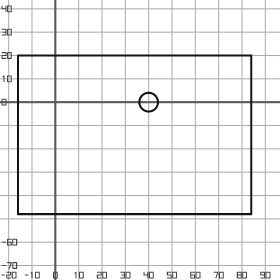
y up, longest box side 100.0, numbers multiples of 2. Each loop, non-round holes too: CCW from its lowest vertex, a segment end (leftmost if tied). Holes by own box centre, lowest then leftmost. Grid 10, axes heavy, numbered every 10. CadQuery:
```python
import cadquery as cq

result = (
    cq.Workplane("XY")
    .moveTo(-16.0, -48.0)
    .lineTo(84.0, -48.0)
    .lineTo(84.0, 20.0)
    .lineTo(-16.0, 20.0)
    .close()
    .moveTo(40.0, 0.0)
    .circle(4.0)
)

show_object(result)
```